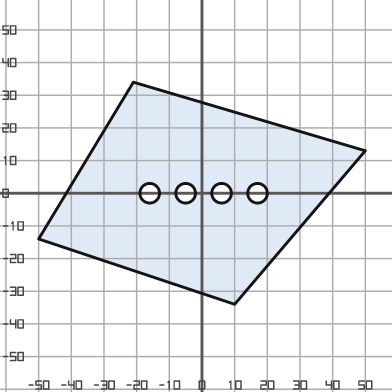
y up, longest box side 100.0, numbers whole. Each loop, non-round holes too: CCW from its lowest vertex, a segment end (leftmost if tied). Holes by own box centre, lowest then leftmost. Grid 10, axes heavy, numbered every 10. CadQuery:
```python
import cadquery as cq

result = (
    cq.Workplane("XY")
    .moveTo(10.0, -34.0)
    .lineTo(50.0, 13.0)
    .lineTo(-21.0, 34.0)
    .lineTo(-50.0, -14.0)
    .close()
    .moveTo(-16.0, 0.0)
    .circle(3.0)
    .moveTo(-5.0, 0.0)
    .circle(3.0)
    .moveTo(6.0, 0.0)
    .circle(3.0)
    .moveTo(17.0, 0.0)
    .circle(3.0)
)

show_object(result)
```